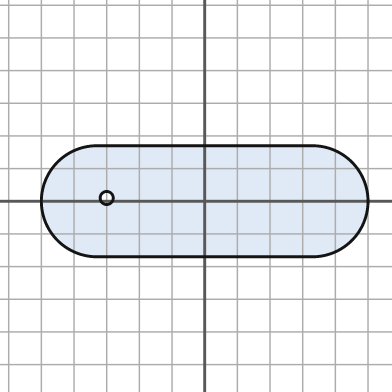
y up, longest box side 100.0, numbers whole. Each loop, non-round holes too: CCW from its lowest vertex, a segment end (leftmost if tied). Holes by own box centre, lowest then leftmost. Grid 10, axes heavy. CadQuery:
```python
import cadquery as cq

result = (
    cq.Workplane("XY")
    .moveTo(-33.0, -17.0)
    .lineTo(33.0, -17.0)
    .threePointArc((50.0, 0.0), (33.0, 17.0))
    .lineTo(-33.0, 17.0)
    .threePointArc((-50.0, 0.0), (-33.0, -17.0))
    .close()
    .moveTo(-30.0, 1.0)
    .circle(2.0)
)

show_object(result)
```